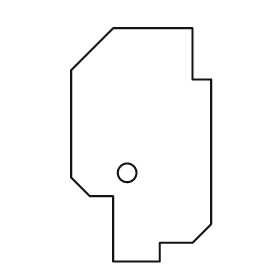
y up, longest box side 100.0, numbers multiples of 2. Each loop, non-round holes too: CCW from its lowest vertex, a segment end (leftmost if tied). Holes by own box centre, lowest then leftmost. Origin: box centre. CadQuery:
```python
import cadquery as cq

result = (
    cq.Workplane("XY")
    .moveTo(-12.0, -50.0)
    .lineTo(8.0, -50.0)
    .lineTo(8.0, -42.0)
    .lineTo(22.0, -42.0)
    .lineTo(30.0, -34.0)
    .lineTo(30.0, 28.0)
    .lineTo(22.0, 28.0)
    .lineTo(22.0, 50.0)
    .lineTo(-12.0, 50.0)
    .lineTo(-30.0, 32.0)
    .lineTo(-30.0, -14.0)
    .lineTo(-22.0, -22.0)
    .lineTo(-12.0, -22.0)
    .close()
    .moveTo(-6.0, -12.0)
    .circle(4.0)
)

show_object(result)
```